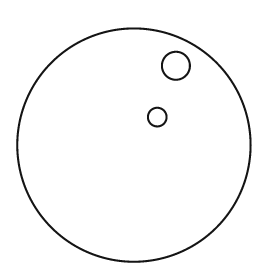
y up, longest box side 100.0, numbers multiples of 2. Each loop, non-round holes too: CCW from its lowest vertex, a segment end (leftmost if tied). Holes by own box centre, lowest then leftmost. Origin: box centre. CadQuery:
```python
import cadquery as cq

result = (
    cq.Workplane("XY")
    .moveTo(0.0, 0.0)
    .circle(50.0)
    .moveTo(10.0, 12.0)
    .circle(4.0)
    .moveTo(18.0, 34.0)
    .circle(6.0)
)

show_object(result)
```